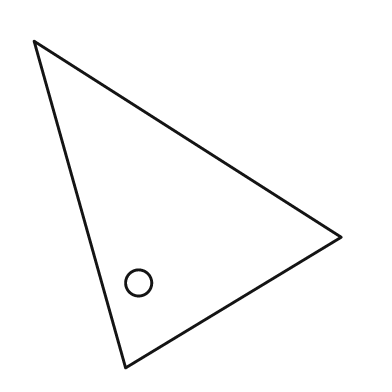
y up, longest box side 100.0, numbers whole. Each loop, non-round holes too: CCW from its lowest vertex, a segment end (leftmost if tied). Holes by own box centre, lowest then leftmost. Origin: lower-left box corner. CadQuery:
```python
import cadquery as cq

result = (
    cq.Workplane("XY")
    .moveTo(28.0, 0.0)
    .lineTo(94.0, 40.0)
    .lineTo(0.0, 100.0)
    .close()
    .moveTo(32.0, 26.0)
    .circle(4.0)
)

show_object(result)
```